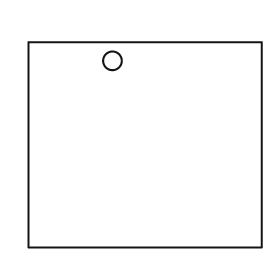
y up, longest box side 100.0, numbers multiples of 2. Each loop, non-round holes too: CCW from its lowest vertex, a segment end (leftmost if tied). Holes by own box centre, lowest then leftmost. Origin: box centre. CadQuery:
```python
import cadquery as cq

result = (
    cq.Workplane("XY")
    .moveTo(-50.0, -44.0)
    .lineTo(50.0, -44.0)
    .lineTo(50.0, 44.0)
    .lineTo(-50.0, 44.0)
    .close()
    .moveTo(-14.0, 36.0)
    .circle(4.0)
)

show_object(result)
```